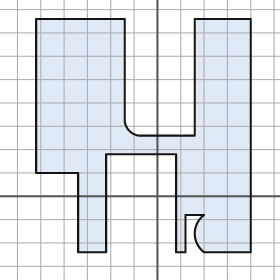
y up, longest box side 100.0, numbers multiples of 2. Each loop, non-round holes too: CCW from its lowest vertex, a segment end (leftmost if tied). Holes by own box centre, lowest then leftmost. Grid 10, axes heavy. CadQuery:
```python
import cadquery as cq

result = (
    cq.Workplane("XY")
    .moveTo(-34.0, -24.0)
    .lineTo(-22.0, -24.0)
    .lineTo(-22.0, 18.0)
    .lineTo(8.0, 18.0)
    .lineTo(8.0, -24.0)
    .lineTo(12.0, -24.0)
    .lineTo(12.0, -8.0)
    .lineTo(20.0, -8.0)
    .threePointArc((16.0, -16.0), (20.0, -24.0))
    .lineTo(40.0, -24.0)
    .lineTo(40.0, 76.0)
    .lineTo(16.0, 76.0)
    .lineTo(16.0, 26.0)
    .lineTo(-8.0, 26.0)
    .threePointArc((-12.0, 28.0), (-14.0, 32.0))
    .lineTo(-14.0, 76.0)
    .lineTo(-52.0, 76.0)
    .lineTo(-52.0, 10.0)
    .lineTo(-34.0, 10.0)
    .close()
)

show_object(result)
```